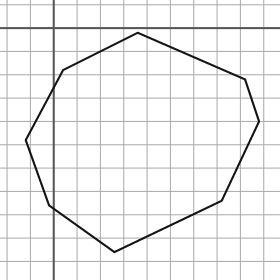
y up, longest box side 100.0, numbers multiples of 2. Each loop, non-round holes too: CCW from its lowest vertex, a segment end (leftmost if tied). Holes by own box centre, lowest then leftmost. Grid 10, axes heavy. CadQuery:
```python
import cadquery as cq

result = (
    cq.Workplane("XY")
    .moveTo(26.0, -96.0)
    .lineTo(72.0, -74.0)
    .lineTo(88.0, -40.0)
    .lineTo(82.0, -22.0)
    .lineTo(36.0, -2.0)
    .lineTo(4.0, -18.0)
    .lineTo(-12.0, -48.0)
    .lineTo(-2.0, -76.0)
    .close()
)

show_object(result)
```